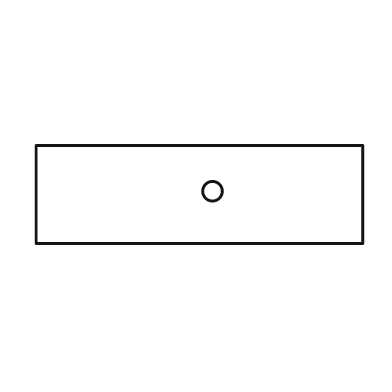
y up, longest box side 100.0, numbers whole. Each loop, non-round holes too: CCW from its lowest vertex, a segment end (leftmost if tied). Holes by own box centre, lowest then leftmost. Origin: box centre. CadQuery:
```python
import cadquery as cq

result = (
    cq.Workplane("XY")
    .moveTo(-50.0, -15.0)
    .lineTo(50.0, -15.0)
    .lineTo(50.0, 15.0)
    .lineTo(-50.0, 15.0)
    .close()
    .moveTo(4.0, 1.0)
    .circle(3.0)
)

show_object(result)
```